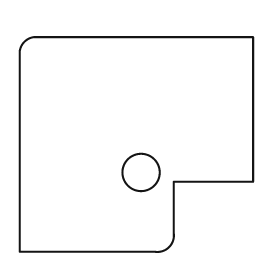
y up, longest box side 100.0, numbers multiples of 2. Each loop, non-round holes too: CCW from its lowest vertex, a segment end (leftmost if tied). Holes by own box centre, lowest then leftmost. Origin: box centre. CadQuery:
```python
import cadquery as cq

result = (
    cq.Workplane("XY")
    .moveTo(-50.0, -46.0)
    .lineTo(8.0, -46.0)
    .threePointArc((14.0, -44.0), (16.0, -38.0))
    .lineTo(16.0, -16.0)
    .lineTo(50.0, -16.0)
    .lineTo(50.0, 46.0)
    .lineTo(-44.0, 46.0)
    .threePointArc((-48.0, 44.0), (-50.0, 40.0))
    .close()
    .moveTo(2.0, -12.0)
    .circle(8.0)
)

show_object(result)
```